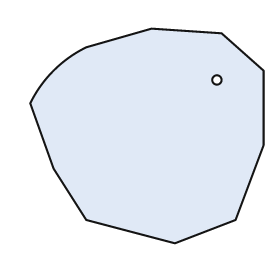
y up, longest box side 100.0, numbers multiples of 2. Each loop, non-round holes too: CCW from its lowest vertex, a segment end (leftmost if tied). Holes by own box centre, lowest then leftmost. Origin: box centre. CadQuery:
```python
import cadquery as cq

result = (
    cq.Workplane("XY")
    .moveTo(12.0, -46.0)
    .lineTo(38.0, -36.0)
    .lineTo(50.0, -4.0)
    .lineTo(50.0, 28.0)
    .lineTo(32.0, 44.0)
    .lineTo(2.0, 46.0)
    .lineTo(-26.0, 38.0)
    .threePointArc((-40.0, 28.0), (-50.0, 14.0))
    .lineTo(-40.0, -14.0)
    .lineTo(-26.0, -36.0)
    .close()
    .moveTo(30.0, 24.0)
    .circle(2.0)
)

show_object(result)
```